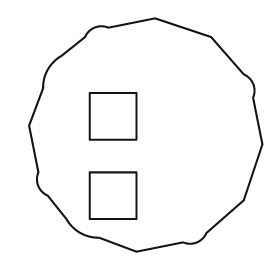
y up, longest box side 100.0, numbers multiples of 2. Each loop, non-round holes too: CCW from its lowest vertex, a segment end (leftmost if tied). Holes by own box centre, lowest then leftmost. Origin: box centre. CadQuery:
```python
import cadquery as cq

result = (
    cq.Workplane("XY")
    .moveTo(-4.0, -50.0)
    .lineTo(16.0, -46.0)
    .threePointArc((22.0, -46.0), (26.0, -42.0))
    .lineTo(42.0, -28.0)
    .lineTo(50.0, -4.0)
    .lineTo(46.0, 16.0)
    .threePointArc((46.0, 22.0), (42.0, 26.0))
    .lineTo(28.0, 42.0)
    .lineTo(4.0, 50.0)
    .lineTo(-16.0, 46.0)
    .threePointArc((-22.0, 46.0), (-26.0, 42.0))
    .lineTo(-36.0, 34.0)
    .threePointArc((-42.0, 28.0), (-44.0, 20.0))
    .lineTo(-50.0, 4.0)
    .lineTo(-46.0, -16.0)
    .threePointArc((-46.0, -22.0), (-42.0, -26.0))
    .lineTo(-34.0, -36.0)
    .threePointArc((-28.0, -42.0), (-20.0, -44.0))
    .close()
    .moveTo(-24.0, -36.0)
    .lineTo(-4.0, -36.0)
    .lineTo(-4.0, -16.0)
    .lineTo(-24.0, -16.0)
    .close()
    .moveTo(-24.0, -2.0)
    .lineTo(-4.0, -2.0)
    .lineTo(-4.0, 18.0)
    .lineTo(-24.0, 18.0)
    .close()
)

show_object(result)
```